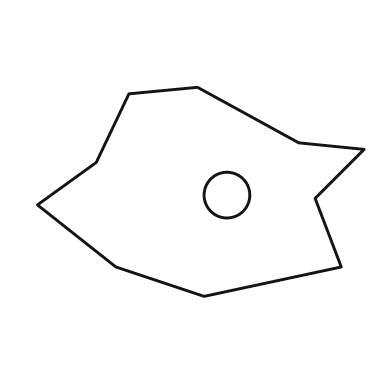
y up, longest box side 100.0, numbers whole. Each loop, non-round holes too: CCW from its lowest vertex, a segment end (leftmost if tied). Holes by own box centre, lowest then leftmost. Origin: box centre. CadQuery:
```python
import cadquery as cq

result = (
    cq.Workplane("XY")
    .moveTo(1.0, -32.0)
    .lineTo(43.0, -23.0)
    .lineTo(35.0, -2.0)
    .lineTo(50.0, 13.0)
    .lineTo(30.0, 15.0)
    .lineTo(-1.0, 32.0)
    .lineTo(-22.0, 30.0)
    .lineTo(-32.0, 9.0)
    .lineTo(-50.0, -4.0)
    .lineTo(-26.0, -23.0)
    .close()
    .moveTo(8.0, -1.0)
    .circle(7.0)
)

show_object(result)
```